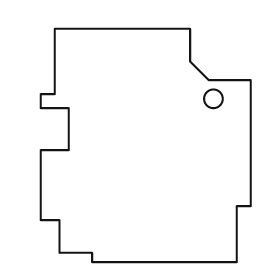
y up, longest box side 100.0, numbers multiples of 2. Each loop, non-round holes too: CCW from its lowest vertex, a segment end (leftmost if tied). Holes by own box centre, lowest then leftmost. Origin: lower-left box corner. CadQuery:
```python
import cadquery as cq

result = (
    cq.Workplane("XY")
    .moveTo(22.0, 0.0)
    .lineTo(84.0, 0.0)
    .lineTo(84.0, 24.0)
    .lineTo(90.0, 24.0)
    .lineTo(90.0, 78.0)
    .lineTo(72.0, 78.0)
    .lineTo(64.0, 86.0)
    .lineTo(64.0, 100.0)
    .lineTo(6.0, 100.0)
    .lineTo(6.0, 72.0)
    .lineTo(0.0, 72.0)
    .lineTo(0.0, 66.0)
    .lineTo(12.0, 66.0)
    .lineTo(12.0, 48.0)
    .lineTo(0.0, 48.0)
    .lineTo(0.0, 18.0)
    .lineTo(8.0, 18.0)
    .lineTo(8.0, 4.0)
    .lineTo(22.0, 4.0)
    .close()
    .moveTo(74.0, 70.0)
    .circle(4.0)
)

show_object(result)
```